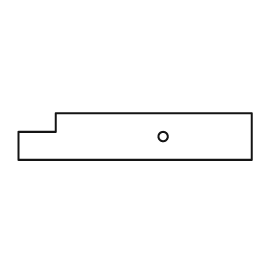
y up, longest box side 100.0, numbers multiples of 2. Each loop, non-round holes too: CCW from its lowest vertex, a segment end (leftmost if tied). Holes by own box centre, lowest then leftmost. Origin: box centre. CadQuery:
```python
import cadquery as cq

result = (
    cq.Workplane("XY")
    .moveTo(-50.0, -10.0)
    .lineTo(50.0, -10.0)
    .lineTo(50.0, 10.0)
    .lineTo(-34.0, 10.0)
    .lineTo(-34.0, 2.0)
    .lineTo(-50.0, 2.0)
    .close()
    .moveTo(12.0, 0.0)
    .circle(2.0)
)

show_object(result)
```